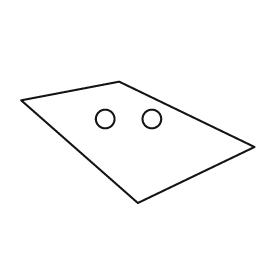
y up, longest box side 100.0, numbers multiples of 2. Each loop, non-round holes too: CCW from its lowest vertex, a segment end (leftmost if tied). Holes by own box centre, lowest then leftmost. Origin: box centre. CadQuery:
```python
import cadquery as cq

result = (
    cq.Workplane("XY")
    .moveTo(0.0, -26.0)
    .lineTo(50.0, -2.0)
    .lineTo(-8.0, 26.0)
    .lineTo(-50.0, 18.0)
    .close()
    .moveTo(-14.0, 10.0)
    .circle(4.0)
    .moveTo(6.0, 10.0)
    .circle(4.0)
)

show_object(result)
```